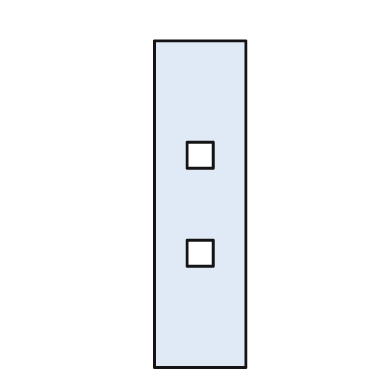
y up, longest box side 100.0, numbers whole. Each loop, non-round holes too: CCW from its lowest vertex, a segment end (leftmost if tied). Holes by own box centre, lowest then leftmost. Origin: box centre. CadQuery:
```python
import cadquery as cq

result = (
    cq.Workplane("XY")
    .moveTo(-14.0, -50.0)
    .lineTo(14.0, -50.0)
    .lineTo(14.0, 50.0)
    .lineTo(-14.0, 50.0)
    .close()
    .moveTo(-4.0, -19.0)
    .lineTo(4.0, -19.0)
    .lineTo(4.0, -11.0)
    .lineTo(-4.0, -11.0)
    .close()
    .moveTo(-4.0, 11.0)
    .lineTo(4.0, 11.0)
    .lineTo(4.0, 19.0)
    .lineTo(-4.0, 19.0)
    .close()
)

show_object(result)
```